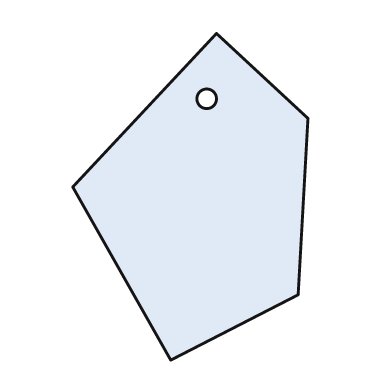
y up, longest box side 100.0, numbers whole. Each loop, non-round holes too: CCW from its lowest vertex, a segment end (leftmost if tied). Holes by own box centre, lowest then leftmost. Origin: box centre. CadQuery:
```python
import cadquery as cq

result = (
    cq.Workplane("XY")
    .moveTo(-6.0, -50.0)
    .lineTo(33.0, -30.0)
    .lineTo(36.0, 24.0)
    .lineTo(8.0, 50.0)
    .lineTo(-36.0, 3.0)
    .close()
    .moveTo(5.0, 30.0)
    .circle(3.0)
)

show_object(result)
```